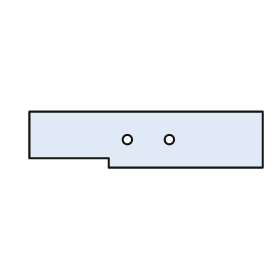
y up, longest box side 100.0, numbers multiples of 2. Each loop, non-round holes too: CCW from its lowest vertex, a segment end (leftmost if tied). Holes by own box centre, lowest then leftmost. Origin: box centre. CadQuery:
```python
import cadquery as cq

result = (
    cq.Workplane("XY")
    .moveTo(-16.0, -12.0)
    .lineTo(50.0, -12.0)
    .lineTo(50.0, 12.0)
    .lineTo(-50.0, 12.0)
    .lineTo(-50.0, -8.0)
    .lineTo(-16.0, -8.0)
    .close()
    .moveTo(-8.0, 0.0)
    .circle(2.0)
    .moveTo(10.0, 0.0)
    .circle(2.0)
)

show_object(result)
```